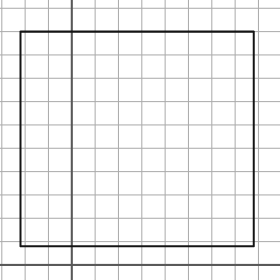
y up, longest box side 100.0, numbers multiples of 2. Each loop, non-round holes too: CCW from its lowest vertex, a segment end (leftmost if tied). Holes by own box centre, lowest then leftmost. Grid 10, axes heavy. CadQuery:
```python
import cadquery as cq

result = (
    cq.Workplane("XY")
    .moveTo(-22.0, 8.0)
    .lineTo(78.0, 8.0)
    .lineTo(78.0, 100.0)
    .lineTo(-22.0, 100.0)
    .close()
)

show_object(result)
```